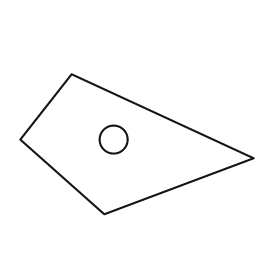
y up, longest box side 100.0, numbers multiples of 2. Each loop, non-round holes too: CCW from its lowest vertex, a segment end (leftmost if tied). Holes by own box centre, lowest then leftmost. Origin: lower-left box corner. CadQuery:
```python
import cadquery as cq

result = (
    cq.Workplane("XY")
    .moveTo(36.0, 0.0)
    .lineTo(100.0, 24.0)
    .lineTo(22.0, 60.0)
    .lineTo(0.0, 32.0)
    .close()
    .moveTo(40.0, 32.0)
    .circle(6.0)
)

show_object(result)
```